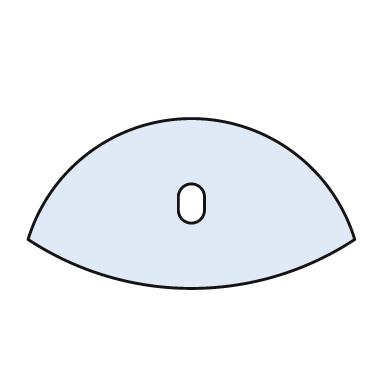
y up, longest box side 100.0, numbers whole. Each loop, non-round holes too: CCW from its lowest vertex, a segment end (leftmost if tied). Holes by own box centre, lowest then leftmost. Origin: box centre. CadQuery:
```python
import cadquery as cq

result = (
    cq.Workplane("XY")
    .moveTo(-50.0, -11.0)
    .threePointArc((0.0, -26.0), (50.0, -11.0))
    .threePointArc((0.0, 26.0), (-50.0, -11.0))
    .close()
    .moveTo(-4.0, -2.0)
    .threePointArc((0.0, -6.0), (4.0, -2.0))
    .lineTo(4.0, 2.0)
    .threePointArc((0.0, 6.0), (-4.0, 2.0))
    .close()
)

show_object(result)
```